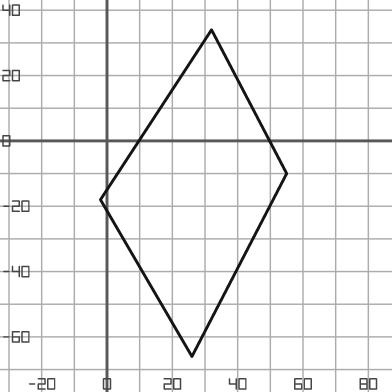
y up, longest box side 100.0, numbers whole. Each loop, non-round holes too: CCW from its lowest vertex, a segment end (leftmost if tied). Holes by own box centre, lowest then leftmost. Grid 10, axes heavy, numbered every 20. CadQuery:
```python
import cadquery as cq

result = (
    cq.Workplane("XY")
    .moveTo(26.0, -66.0)
    .lineTo(55.0, -10.0)
    .lineTo(32.0, 34.0)
    .lineTo(-2.0, -18.0)
    .close()
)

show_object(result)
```